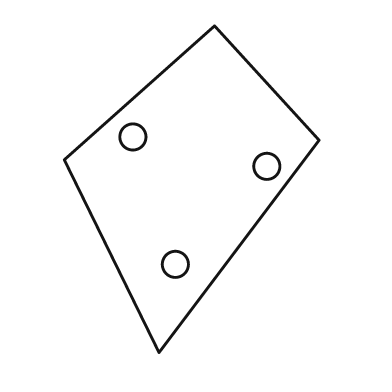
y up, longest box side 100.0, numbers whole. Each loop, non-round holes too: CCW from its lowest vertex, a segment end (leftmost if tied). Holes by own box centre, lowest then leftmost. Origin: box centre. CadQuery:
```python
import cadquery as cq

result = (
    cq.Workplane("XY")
    .moveTo(-10.0, -50.0)
    .lineTo(39.0, 15.0)
    .lineTo(7.0, 50.0)
    .lineTo(-39.0, 9.0)
    .close()
    .moveTo(-5.0, -23.0)
    .circle(4.0)
    .moveTo(23.0, 7.0)
    .circle(4.0)
    .moveTo(-18.0, 16.0)
    .circle(4.0)
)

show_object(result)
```